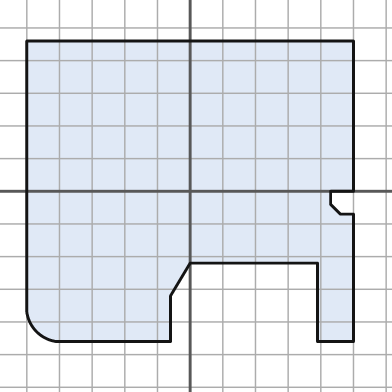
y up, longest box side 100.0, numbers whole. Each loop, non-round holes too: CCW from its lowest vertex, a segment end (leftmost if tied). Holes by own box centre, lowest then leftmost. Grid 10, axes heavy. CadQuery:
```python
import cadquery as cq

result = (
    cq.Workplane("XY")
    .moveTo(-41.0, -46.0)
    .lineTo(-6.0, -46.0)
    .lineTo(-6.0, -32.0)
    .lineTo(0.0, -22.0)
    .lineTo(39.0, -22.0)
    .lineTo(39.0, -46.0)
    .lineTo(50.0, -46.0)
    .lineTo(50.0, -7.0)
    .lineTo(46.0, -7.0)
    .lineTo(43.0, -4.0)
    .lineTo(43.0, 0.0)
    .lineTo(50.0, 0.0)
    .lineTo(50.0, 46.0)
    .lineTo(-50.0, 46.0)
    .lineTo(-50.0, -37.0)
    .threePointArc((-47.0, -43.0), (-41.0, -46.0))
    .close()
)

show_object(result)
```